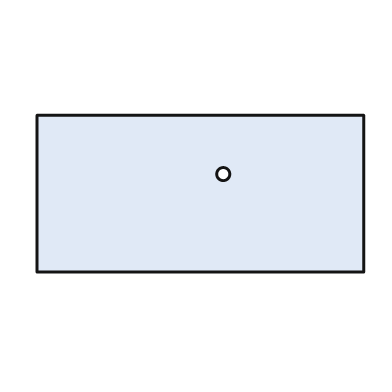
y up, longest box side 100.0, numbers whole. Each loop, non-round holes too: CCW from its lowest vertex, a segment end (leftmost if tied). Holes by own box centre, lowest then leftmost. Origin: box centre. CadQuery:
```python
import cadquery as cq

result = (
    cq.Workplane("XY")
    .moveTo(-50.0, -24.0)
    .lineTo(50.0, -24.0)
    .lineTo(50.0, 24.0)
    .lineTo(-50.0, 24.0)
    .close()
    .moveTo(7.0, 6.0)
    .circle(2.0)
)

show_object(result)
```